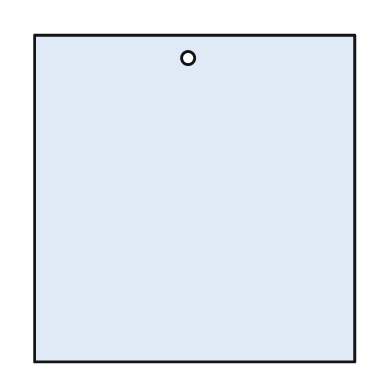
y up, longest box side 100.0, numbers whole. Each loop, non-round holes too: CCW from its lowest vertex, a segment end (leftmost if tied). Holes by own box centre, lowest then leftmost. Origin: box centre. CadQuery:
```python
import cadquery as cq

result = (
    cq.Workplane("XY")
    .moveTo(-49.0, -50.0)
    .lineTo(49.0, -50.0)
    .lineTo(49.0, 50.0)
    .lineTo(-49.0, 50.0)
    .close()
    .moveTo(-2.0, 43.0)
    .circle(2.0)
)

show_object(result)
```